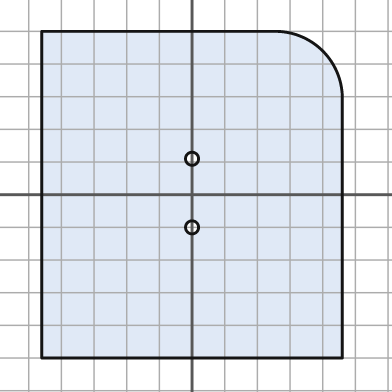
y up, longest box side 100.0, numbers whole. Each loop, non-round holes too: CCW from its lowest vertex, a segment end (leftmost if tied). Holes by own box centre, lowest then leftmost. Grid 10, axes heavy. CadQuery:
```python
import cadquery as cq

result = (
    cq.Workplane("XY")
    .moveTo(-46.0, -50.0)
    .lineTo(46.0, -50.0)
    .lineTo(46.0, 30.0)
    .threePointArc((40.0, 44.0), (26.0, 50.0))
    .lineTo(-46.0, 50.0)
    .close()
    .moveTo(0.0, -10.0)
    .circle(2.0)
    .moveTo(0.0, 11.0)
    .circle(2.0)
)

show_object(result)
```